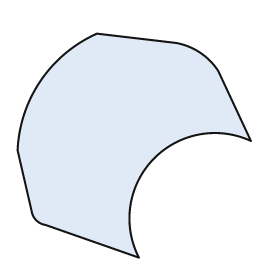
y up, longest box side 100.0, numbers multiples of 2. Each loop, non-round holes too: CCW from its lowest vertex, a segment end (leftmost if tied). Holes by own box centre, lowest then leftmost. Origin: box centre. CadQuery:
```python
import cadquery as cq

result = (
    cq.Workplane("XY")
    .moveTo(2.0, -48.0)
    .threePointArc((8.0, -6.0), (50.0, 2.0))
    .lineTo(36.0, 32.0)
    .threePointArc((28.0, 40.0), (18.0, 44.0))
    .lineTo(-16.0, 48.0)
    .threePointArc((-40.0, 28.0), (-50.0, -2.0))
    .lineTo(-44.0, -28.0)
    .threePointArc((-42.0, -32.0), (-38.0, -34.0))
    .close()
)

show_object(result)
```